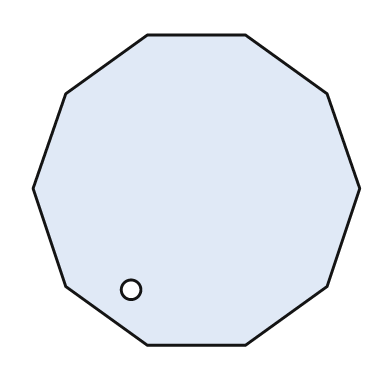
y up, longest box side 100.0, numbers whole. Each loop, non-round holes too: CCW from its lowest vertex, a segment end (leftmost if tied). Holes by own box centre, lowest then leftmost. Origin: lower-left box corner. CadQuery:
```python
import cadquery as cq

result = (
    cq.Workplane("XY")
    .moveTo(35.0, 0.0)
    .lineTo(65.0, 0.0)
    .lineTo(90.0, 18.0)
    .lineTo(100.0, 48.0)
    .lineTo(90.0, 77.0)
    .lineTo(65.0, 95.0)
    .lineTo(35.0, 95.0)
    .lineTo(10.0, 77.0)
    .lineTo(0.0, 48.0)
    .lineTo(10.0, 18.0)
    .close()
    .moveTo(30.0, 17.0)
    .circle(3.0)
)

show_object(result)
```